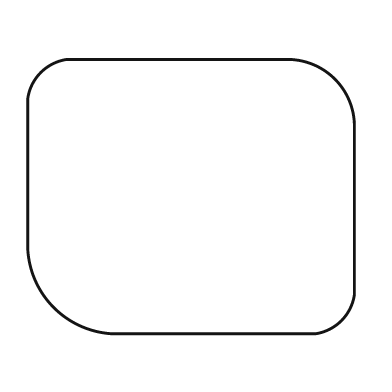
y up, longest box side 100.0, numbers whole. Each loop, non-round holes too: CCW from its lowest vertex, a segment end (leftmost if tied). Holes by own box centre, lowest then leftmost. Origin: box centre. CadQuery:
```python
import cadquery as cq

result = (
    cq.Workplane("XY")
    .moveTo(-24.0, -42.0)
    .lineTo(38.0, -42.0)
    .threePointArc((46.0, -38.0), (50.0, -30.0))
    .lineTo(50.0, 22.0)
    .threePointArc((44.0, 36.0), (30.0, 42.0))
    .lineTo(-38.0, 42.0)
    .threePointArc((-46.0, 38.0), (-50.0, 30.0))
    .lineTo(-50.0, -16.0)
    .threePointArc((-42.0, -34.0), (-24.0, -42.0))
    .close()
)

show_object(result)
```